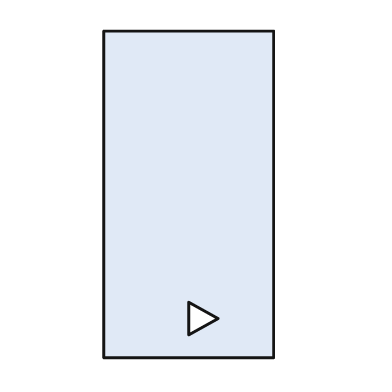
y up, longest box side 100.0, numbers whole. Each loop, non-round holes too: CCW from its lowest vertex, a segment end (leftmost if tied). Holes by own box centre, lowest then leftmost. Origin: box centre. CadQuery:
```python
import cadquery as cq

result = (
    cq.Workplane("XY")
    .moveTo(-26.0, -50.0)
    .lineTo(26.0, -50.0)
    .lineTo(26.0, 50.0)
    .lineTo(-26.0, 50.0)
    .close()
    .moveTo(0.0, -43.0)
    .lineTo(9.0, -38.0)
    .lineTo(0.0, -33.0)
    .close()
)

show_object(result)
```